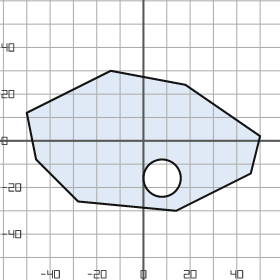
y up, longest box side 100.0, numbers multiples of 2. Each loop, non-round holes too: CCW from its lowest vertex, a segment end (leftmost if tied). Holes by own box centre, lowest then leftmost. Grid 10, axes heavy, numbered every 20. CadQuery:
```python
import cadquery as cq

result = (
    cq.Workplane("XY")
    .moveTo(14.0, -30.0)
    .lineTo(46.0, -14.0)
    .lineTo(50.0, 2.0)
    .lineTo(18.0, 24.0)
    .lineTo(-14.0, 30.0)
    .lineTo(-50.0, 12.0)
    .lineTo(-46.0, -8.0)
    .lineTo(-28.0, -26.0)
    .close()
    .moveTo(8.0, -16.0)
    .circle(8.0)
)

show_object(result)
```